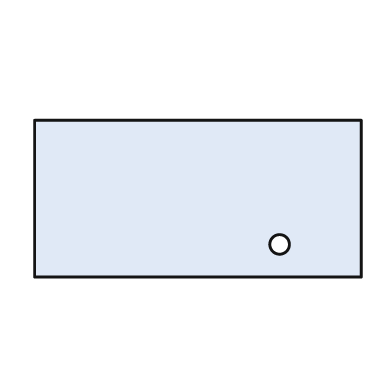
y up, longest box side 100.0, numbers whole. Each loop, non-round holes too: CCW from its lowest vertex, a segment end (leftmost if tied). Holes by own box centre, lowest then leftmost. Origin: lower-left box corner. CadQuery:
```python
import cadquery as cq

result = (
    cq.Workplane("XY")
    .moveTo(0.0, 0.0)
    .lineTo(100.0, 0.0)
    .lineTo(100.0, 48.0)
    .lineTo(0.0, 48.0)
    .close()
    .moveTo(75.0, 10.0)
    .circle(3.0)
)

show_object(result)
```